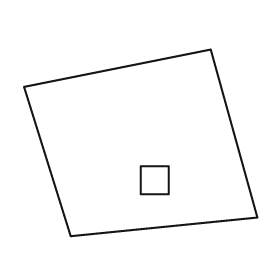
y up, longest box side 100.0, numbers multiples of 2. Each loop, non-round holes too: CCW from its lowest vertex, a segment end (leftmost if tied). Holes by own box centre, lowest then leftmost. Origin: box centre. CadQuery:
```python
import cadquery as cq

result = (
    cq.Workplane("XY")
    .moveTo(-30.0, -40.0)
    .lineTo(50.0, -32.0)
    .lineTo(30.0, 40.0)
    .lineTo(-50.0, 24.0)
    .close()
    .moveTo(0.0, -22.0)
    .lineTo(12.0, -22.0)
    .lineTo(12.0, -10.0)
    .lineTo(0.0, -10.0)
    .close()
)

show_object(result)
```